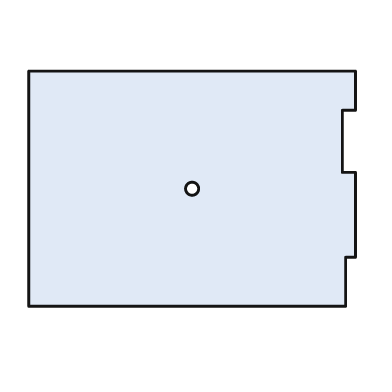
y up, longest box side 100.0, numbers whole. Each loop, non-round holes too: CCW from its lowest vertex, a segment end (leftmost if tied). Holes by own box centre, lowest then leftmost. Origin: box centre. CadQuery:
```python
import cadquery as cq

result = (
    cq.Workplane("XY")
    .moveTo(-50.0, -36.0)
    .lineTo(47.0, -36.0)
    .lineTo(47.0, -21.0)
    .lineTo(50.0, -21.0)
    .lineTo(50.0, 5.0)
    .lineTo(46.0, 5.0)
    .lineTo(46.0, 24.0)
    .lineTo(50.0, 24.0)
    .lineTo(50.0, 36.0)
    .lineTo(-50.0, 36.0)
    .close()
    .moveTo(0.0, 0.0)
    .circle(2.0)
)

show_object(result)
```